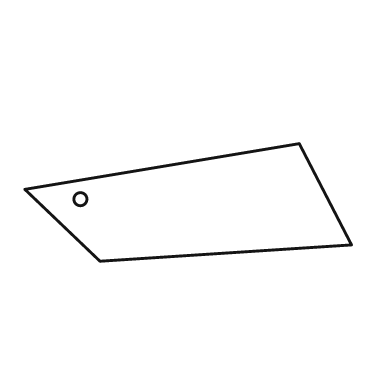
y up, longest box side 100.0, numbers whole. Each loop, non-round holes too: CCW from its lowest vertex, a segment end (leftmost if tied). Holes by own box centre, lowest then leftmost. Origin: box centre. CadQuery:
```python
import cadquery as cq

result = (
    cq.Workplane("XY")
    .moveTo(-27.0, -18.0)
    .lineTo(50.0, -13.0)
    .lineTo(34.0, 18.0)
    .lineTo(-50.0, 4.0)
    .close()
    .moveTo(-33.0, 1.0)
    .circle(2.0)
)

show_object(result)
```